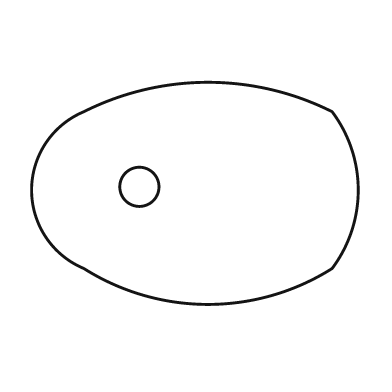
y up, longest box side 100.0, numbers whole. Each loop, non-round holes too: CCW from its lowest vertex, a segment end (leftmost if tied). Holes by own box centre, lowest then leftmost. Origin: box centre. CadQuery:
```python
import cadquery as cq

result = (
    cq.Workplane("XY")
    .moveTo(-34.0, -23.0)
    .threePointArc((4.0, -34.0), (42.0, -23.0))
    .threePointArc((50.0, 1.0), (42.0, 25.0))
    .threePointArc((4.0, 34.0), (-34.0, 25.0))
    .threePointArc((-50.0, 1.0), (-34.0, -23.0))
    .close()
    .moveTo(-17.0, 2.0)
    .circle(6.0)
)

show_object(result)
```